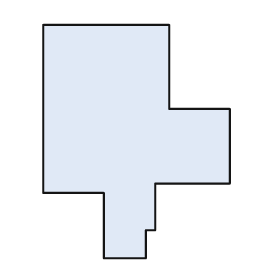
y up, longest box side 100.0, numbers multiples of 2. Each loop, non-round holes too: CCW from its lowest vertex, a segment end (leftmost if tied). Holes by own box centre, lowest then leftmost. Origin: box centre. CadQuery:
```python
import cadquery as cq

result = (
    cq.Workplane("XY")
    .moveTo(-14.0, -50.0)
    .lineTo(4.0, -50.0)
    .lineTo(4.0, -38.0)
    .lineTo(8.0, -38.0)
    .lineTo(8.0, -18.0)
    .lineTo(40.0, -18.0)
    .lineTo(40.0, 14.0)
    .lineTo(14.0, 14.0)
    .lineTo(14.0, 50.0)
    .lineTo(-40.0, 50.0)
    .lineTo(-40.0, -22.0)
    .lineTo(-14.0, -22.0)
    .close()
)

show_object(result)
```